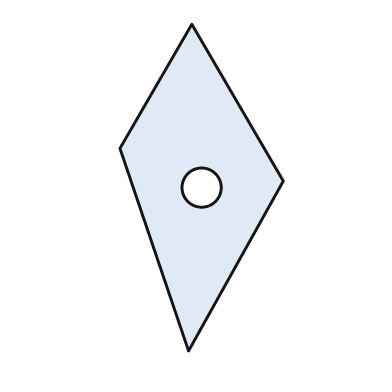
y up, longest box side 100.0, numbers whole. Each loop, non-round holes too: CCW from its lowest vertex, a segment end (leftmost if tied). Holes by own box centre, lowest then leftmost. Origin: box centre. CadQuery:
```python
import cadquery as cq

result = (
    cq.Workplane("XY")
    .moveTo(-4.0, -50.0)
    .lineTo(25.0, 2.0)
    .lineTo(-3.0, 50.0)
    .lineTo(-25.0, 12.0)
    .close()
    .moveTo(0.0, 0.0)
    .circle(6.0)
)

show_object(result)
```